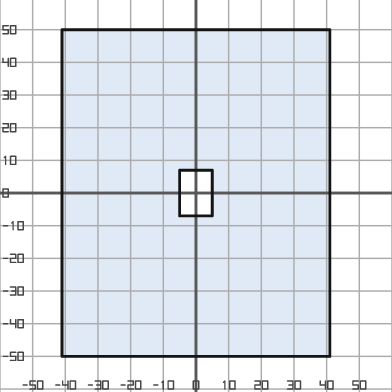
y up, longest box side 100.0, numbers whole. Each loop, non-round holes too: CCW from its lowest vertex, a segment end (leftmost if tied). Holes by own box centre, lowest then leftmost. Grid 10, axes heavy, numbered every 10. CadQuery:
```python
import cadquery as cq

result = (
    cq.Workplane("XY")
    .moveTo(-41.0, -50.0)
    .lineTo(41.0, -50.0)
    .lineTo(41.0, 50.0)
    .lineTo(-41.0, 50.0)
    .close()
    .moveTo(-5.0, -7.0)
    .lineTo(5.0, -7.0)
    .lineTo(5.0, 7.0)
    .lineTo(-5.0, 7.0)
    .close()
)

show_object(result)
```